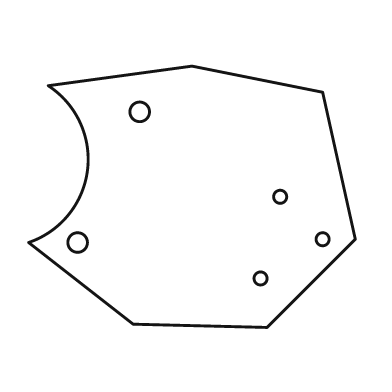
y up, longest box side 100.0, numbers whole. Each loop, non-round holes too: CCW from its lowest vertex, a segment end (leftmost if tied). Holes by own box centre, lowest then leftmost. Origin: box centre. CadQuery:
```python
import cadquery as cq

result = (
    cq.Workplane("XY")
    .moveTo(23.0, -40.0)
    .lineTo(50.0, -13.0)
    .lineTo(40.0, 32.0)
    .lineTo(0.0, 40.0)
    .lineTo(-44.0, 34.0)
    .threePointArc((-32.0, 8.0), (-50.0, -14.0))
    .lineTo(-18.0, -39.0)
    .close()
    .moveTo(21.0, -25.0)
    .circle(2.0)
    .moveTo(-35.0, -14.0)
    .circle(3.0)
    .moveTo(40.0, -13.0)
    .circle(2.0)
    .moveTo(27.0, 0.0)
    .circle(2.0)
    .moveTo(-16.0, 26.0)
    .circle(3.0)
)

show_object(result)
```